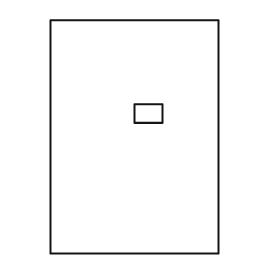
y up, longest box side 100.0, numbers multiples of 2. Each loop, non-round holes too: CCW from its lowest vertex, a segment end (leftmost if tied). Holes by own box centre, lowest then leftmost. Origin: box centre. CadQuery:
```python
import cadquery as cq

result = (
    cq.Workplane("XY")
    .moveTo(-36.0, -50.0)
    .lineTo(36.0, -50.0)
    .lineTo(36.0, 50.0)
    .lineTo(-36.0, 50.0)
    .close()
    .moveTo(0.0, 6.0)
    .lineTo(12.0, 6.0)
    .lineTo(12.0, 14.0)
    .lineTo(0.0, 14.0)
    .close()
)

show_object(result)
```